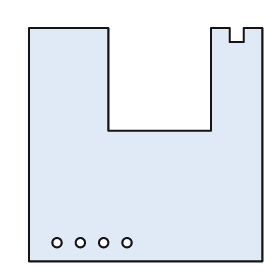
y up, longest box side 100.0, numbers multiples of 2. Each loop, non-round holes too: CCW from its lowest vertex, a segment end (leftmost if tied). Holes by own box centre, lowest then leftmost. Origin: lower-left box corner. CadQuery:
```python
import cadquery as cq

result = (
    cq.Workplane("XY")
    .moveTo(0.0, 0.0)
    .lineTo(100.0, 0.0)
    .lineTo(100.0, 100.0)
    .lineTo(92.0, 100.0)
    .lineTo(92.0, 94.0)
    .lineTo(86.0, 94.0)
    .lineTo(86.0, 100.0)
    .lineTo(78.0, 100.0)
    .lineTo(78.0, 56.0)
    .lineTo(34.0, 56.0)
    .lineTo(34.0, 100.0)
    .lineTo(0.0, 100.0)
    .close()
    .moveTo(12.0, 8.0)
    .circle(2.0)
    .moveTo(22.0, 8.0)
    .circle(2.0)
    .moveTo(32.0, 8.0)
    .circle(2.0)
    .moveTo(42.0, 8.0)
    .circle(2.0)
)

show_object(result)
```